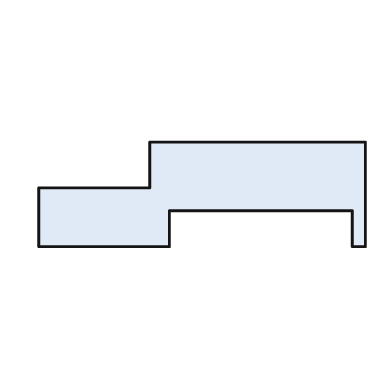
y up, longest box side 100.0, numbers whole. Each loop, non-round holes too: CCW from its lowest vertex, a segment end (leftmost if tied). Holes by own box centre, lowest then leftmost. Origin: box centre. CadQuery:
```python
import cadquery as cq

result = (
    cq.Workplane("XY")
    .moveTo(-50.0, -16.0)
    .lineTo(-10.0, -16.0)
    .lineTo(-10.0, -5.0)
    .lineTo(46.0, -5.0)
    .lineTo(46.0, -16.0)
    .lineTo(50.0, -16.0)
    .lineTo(50.0, 16.0)
    .lineTo(-16.0, 16.0)
    .lineTo(-16.0, 2.0)
    .lineTo(-50.0, 2.0)
    .close()
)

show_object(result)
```